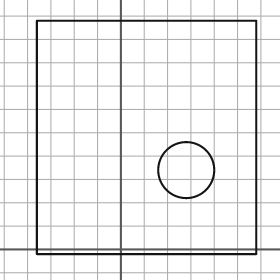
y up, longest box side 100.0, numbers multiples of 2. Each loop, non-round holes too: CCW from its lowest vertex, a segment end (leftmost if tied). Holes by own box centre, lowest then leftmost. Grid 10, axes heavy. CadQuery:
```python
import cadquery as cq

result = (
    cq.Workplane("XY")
    .moveTo(-36.0, -2.0)
    .lineTo(58.0, -2.0)
    .lineTo(58.0, 98.0)
    .lineTo(-36.0, 98.0)
    .close()
    .moveTo(28.0, 34.0)
    .circle(12.0)
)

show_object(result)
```